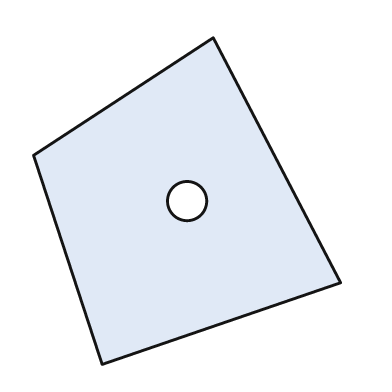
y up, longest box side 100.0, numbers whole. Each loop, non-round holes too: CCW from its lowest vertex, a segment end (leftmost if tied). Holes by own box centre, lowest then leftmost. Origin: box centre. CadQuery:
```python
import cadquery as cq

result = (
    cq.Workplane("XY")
    .moveTo(-26.0, -50.0)
    .lineTo(47.0, -25.0)
    .lineTo(8.0, 50.0)
    .lineTo(-47.0, 14.0)
    .close()
    .moveTo(0.0, 0.0)
    .circle(6.0)
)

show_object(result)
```